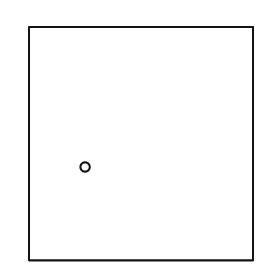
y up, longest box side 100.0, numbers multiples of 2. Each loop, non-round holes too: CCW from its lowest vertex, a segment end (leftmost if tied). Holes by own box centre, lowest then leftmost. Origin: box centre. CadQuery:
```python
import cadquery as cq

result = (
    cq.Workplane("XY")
    .moveTo(-48.0, -50.0)
    .lineTo(48.0, -50.0)
    .lineTo(48.0, 50.0)
    .lineTo(-48.0, 50.0)
    .close()
    .moveTo(-24.0, -10.0)
    .circle(2.0)
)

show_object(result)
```